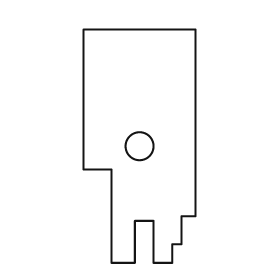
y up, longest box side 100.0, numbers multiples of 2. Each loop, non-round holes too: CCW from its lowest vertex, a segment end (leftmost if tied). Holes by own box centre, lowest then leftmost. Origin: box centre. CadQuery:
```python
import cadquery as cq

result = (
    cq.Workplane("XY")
    .moveTo(-12.0, -50.0)
    .lineTo(-2.0, -50.0)
    .lineTo(-2.0, -32.0)
    .lineTo(6.0, -32.0)
    .lineTo(6.0, -50.0)
    .lineTo(14.0, -50.0)
    .lineTo(14.0, -42.0)
    .lineTo(18.0, -42.0)
    .lineTo(18.0, -30.0)
    .lineTo(24.0, -30.0)
    .lineTo(24.0, 50.0)
    .lineTo(-24.0, 50.0)
    .lineTo(-24.0, -10.0)
    .lineTo(-12.0, -10.0)
    .close()
    .moveTo(0.0, 0.0)
    .circle(6.0)
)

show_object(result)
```